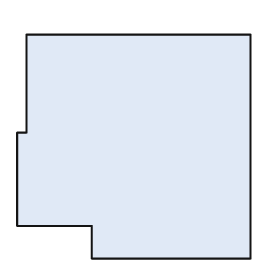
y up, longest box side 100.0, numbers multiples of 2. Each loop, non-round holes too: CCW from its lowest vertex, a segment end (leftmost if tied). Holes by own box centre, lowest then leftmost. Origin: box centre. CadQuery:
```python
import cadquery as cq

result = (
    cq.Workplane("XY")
    .moveTo(-18.0, -48.0)
    .lineTo(50.0, -48.0)
    .lineTo(50.0, 48.0)
    .lineTo(-46.0, 48.0)
    .lineTo(-46.0, 6.0)
    .lineTo(-50.0, 6.0)
    .lineTo(-50.0, -34.0)
    .lineTo(-18.0, -34.0)
    .close()
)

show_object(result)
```